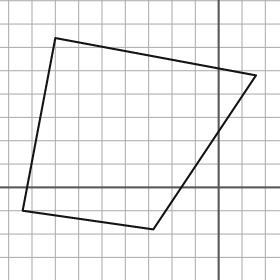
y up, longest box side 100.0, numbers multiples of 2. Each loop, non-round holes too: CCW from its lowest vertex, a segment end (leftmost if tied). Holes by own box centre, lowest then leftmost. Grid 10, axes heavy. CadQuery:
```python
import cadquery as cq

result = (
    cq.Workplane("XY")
    .moveTo(-28.0, -18.0)
    .lineTo(16.0, 48.0)
    .lineTo(-70.0, 64.0)
    .lineTo(-84.0, -10.0)
    .close()
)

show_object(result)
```